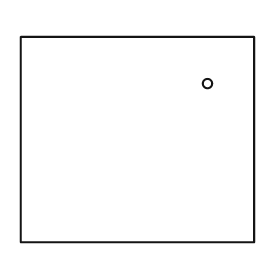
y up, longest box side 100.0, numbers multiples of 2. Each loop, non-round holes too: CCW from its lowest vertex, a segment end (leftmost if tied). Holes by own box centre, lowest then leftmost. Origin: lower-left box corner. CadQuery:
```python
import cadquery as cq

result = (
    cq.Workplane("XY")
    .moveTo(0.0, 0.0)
    .lineTo(100.0, 0.0)
    .lineTo(100.0, 88.0)
    .lineTo(0.0, 88.0)
    .close()
    .moveTo(80.0, 68.0)
    .circle(2.0)
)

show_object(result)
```